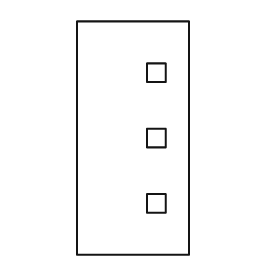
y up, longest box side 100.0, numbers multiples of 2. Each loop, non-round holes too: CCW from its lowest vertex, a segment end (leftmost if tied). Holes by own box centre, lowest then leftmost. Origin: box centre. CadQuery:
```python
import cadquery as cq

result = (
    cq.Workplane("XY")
    .moveTo(-24.0, -50.0)
    .lineTo(24.0, -50.0)
    .lineTo(24.0, 50.0)
    .lineTo(-24.0, 50.0)
    .close()
    .moveTo(6.0, -32.0)
    .lineTo(14.0, -32.0)
    .lineTo(14.0, -24.0)
    .lineTo(6.0, -24.0)
    .close()
    .moveTo(6.0, -4.0)
    .lineTo(14.0, -4.0)
    .lineTo(14.0, 4.0)
    .lineTo(6.0, 4.0)
    .close()
    .moveTo(6.0, 24.0)
    .lineTo(14.0, 24.0)
    .lineTo(14.0, 32.0)
    .lineTo(6.0, 32.0)
    .close()
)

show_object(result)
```